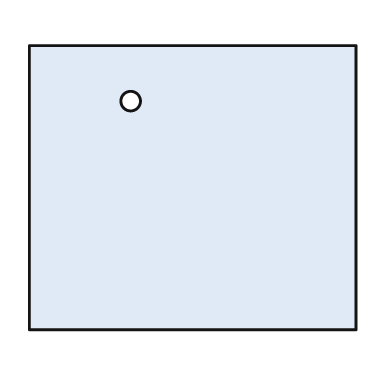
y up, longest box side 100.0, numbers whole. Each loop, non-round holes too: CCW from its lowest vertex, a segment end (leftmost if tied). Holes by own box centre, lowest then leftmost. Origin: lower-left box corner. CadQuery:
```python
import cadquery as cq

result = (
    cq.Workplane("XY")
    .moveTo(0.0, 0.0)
    .lineTo(100.0, 0.0)
    .lineTo(100.0, 87.0)
    .lineTo(0.0, 87.0)
    .close()
    .moveTo(31.0, 70.0)
    .circle(3.0)
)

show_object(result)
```